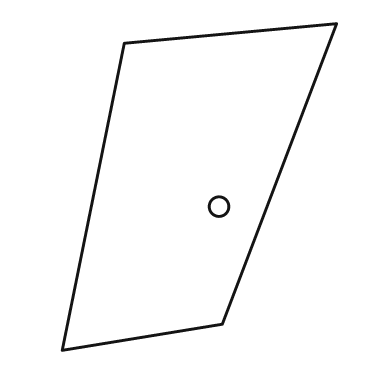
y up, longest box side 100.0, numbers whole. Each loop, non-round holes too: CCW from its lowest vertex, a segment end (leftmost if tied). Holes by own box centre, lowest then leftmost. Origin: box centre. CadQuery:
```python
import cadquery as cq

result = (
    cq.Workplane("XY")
    .moveTo(-42.0, -50.0)
    .lineTo(7.0, -42.0)
    .lineTo(42.0, 50.0)
    .lineTo(-23.0, 44.0)
    .close()
    .moveTo(6.0, -6.0)
    .circle(3.0)
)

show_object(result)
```